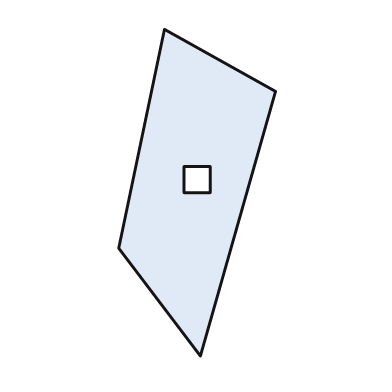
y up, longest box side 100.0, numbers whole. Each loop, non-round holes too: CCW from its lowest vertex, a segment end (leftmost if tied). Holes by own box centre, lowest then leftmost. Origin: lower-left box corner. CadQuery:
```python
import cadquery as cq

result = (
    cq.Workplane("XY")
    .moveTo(25.0, 0.0)
    .lineTo(48.0, 81.0)
    .lineTo(14.0, 100.0)
    .lineTo(0.0, 33.0)
    .close()
    .moveTo(20.0, 50.0)
    .lineTo(28.0, 50.0)
    .lineTo(28.0, 58.0)
    .lineTo(20.0, 58.0)
    .close()
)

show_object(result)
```